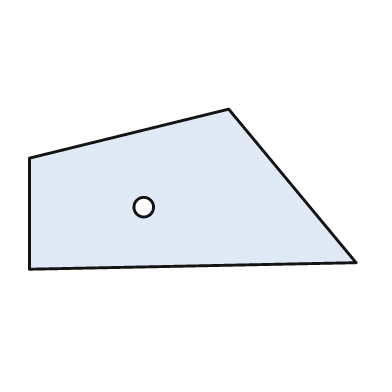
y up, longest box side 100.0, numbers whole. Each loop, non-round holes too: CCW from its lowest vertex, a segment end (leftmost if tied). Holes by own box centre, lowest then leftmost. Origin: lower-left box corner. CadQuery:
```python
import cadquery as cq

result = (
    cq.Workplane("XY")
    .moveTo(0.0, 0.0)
    .lineTo(100.0, 2.0)
    .lineTo(61.0, 49.0)
    .lineTo(0.0, 34.0)
    .close()
    .moveTo(35.0, 19.0)
    .circle(3.0)
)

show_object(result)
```